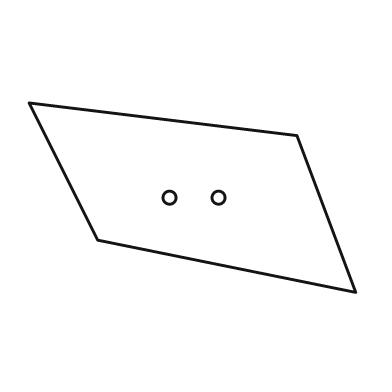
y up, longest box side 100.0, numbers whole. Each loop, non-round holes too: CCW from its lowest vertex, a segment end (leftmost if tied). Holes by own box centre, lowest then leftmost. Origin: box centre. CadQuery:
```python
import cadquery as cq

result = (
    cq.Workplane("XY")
    .moveTo(50.0, -29.0)
    .lineTo(32.0, 19.0)
    .lineTo(-50.0, 29.0)
    .lineTo(-29.0, -13.0)
    .close()
    .moveTo(-7.0, 0.0)
    .circle(2.0)
    .moveTo(8.0, 0.0)
    .circle(2.0)
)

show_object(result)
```